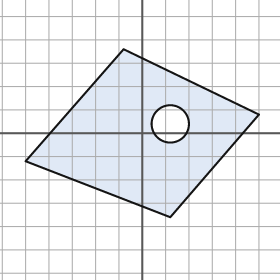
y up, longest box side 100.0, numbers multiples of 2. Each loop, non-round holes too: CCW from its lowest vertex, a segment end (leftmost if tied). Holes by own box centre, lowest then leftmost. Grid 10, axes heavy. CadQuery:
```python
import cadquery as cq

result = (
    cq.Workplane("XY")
    .moveTo(12.0, -36.0)
    .lineTo(50.0, 8.0)
    .lineTo(-8.0, 36.0)
    .lineTo(-50.0, -12.0)
    .close()
    .moveTo(12.0, 4.0)
    .circle(8.0)
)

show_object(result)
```